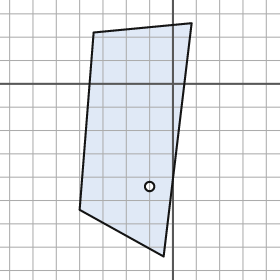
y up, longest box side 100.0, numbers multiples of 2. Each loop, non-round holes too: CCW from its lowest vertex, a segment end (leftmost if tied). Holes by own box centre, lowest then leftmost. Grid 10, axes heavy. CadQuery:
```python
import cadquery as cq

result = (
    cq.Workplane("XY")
    .moveTo(-4.0, -74.0)
    .lineTo(8.0, 26.0)
    .lineTo(-34.0, 22.0)
    .lineTo(-40.0, -54.0)
    .close()
    .moveTo(-10.0, -44.0)
    .circle(2.0)
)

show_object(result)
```